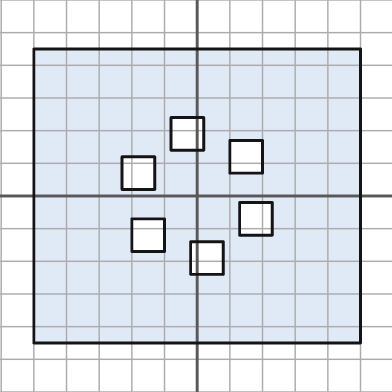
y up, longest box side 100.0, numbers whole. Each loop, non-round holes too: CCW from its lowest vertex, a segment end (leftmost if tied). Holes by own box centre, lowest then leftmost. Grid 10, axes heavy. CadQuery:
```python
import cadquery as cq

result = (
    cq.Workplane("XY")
    .moveTo(-50.0, -45.0)
    .lineTo(50.0, -45.0)
    .lineTo(50.0, 45.0)
    .lineTo(-50.0, 45.0)
    .close()
    .moveTo(-2.0, -24.0)
    .lineTo(8.0, -24.0)
    .lineTo(8.0, -14.0)
    .lineTo(-2.0, -14.0)
    .close()
    .moveTo(-20.0, -17.0)
    .lineTo(-10.0, -17.0)
    .lineTo(-10.0, -7.0)
    .lineTo(-20.0, -7.0)
    .close()
    .moveTo(13.0, -12.0)
    .lineTo(23.0, -12.0)
    .lineTo(23.0, -2.0)
    .lineTo(13.0, -2.0)
    .close()
    .moveTo(-23.0, 2.0)
    .lineTo(-13.0, 2.0)
    .lineTo(-13.0, 12.0)
    .lineTo(-23.0, 12.0)
    .close()
    .moveTo(10.0, 7.0)
    .lineTo(20.0, 7.0)
    .lineTo(20.0, 17.0)
    .lineTo(10.0, 17.0)
    .close()
    .moveTo(-8.0, 14.0)
    .lineTo(2.0, 14.0)
    .lineTo(2.0, 24.0)
    .lineTo(-8.0, 24.0)
    .close()
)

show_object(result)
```